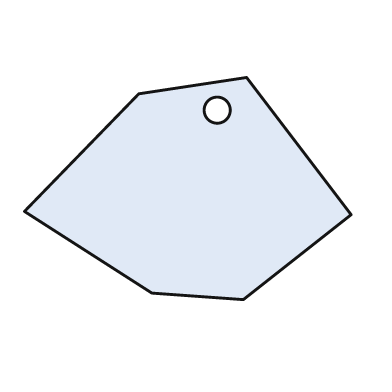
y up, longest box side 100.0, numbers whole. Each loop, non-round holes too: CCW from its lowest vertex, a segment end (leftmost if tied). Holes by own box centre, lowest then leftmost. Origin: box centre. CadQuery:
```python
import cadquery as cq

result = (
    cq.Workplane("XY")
    .moveTo(17.0, -34.0)
    .lineTo(50.0, -8.0)
    .lineTo(18.0, 34.0)
    .lineTo(-15.0, 29.0)
    .lineTo(-50.0, -7.0)
    .lineTo(-11.0, -32.0)
    .close()
    .moveTo(9.0, 24.0)
    .circle(4.0)
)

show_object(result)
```